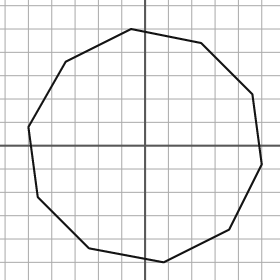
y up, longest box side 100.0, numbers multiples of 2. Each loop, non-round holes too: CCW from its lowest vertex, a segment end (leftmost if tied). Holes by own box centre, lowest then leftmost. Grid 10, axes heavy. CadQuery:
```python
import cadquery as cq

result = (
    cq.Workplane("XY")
    .moveTo(8.0, -50.0)
    .lineTo(36.0, -36.0)
    .lineTo(50.0, -8.0)
    .lineTo(46.0, 22.0)
    .lineTo(24.0, 44.0)
    .lineTo(-6.0, 50.0)
    .lineTo(-34.0, 36.0)
    .lineTo(-50.0, 8.0)
    .lineTo(-46.0, -22.0)
    .lineTo(-24.0, -44.0)
    .close()
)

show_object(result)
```